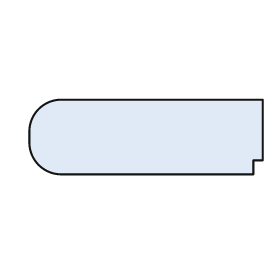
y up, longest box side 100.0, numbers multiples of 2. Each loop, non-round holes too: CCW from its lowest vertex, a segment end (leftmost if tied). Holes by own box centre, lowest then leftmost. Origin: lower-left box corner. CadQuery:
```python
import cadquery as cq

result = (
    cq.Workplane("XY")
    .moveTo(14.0, 0.0)
    .lineTo(96.0, 0.0)
    .lineTo(96.0, 6.0)
    .lineTo(100.0, 6.0)
    .lineTo(100.0, 32.0)
    .lineTo(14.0, 32.0)
    .threePointArc((4.0, 28.0), (0.0, 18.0))
    .lineTo(0.0, 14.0)
    .threePointArc((4.0, 4.0), (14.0, 0.0))
    .close()
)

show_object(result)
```